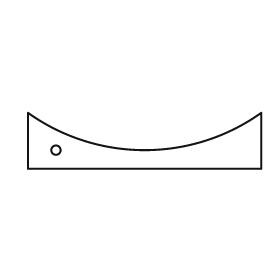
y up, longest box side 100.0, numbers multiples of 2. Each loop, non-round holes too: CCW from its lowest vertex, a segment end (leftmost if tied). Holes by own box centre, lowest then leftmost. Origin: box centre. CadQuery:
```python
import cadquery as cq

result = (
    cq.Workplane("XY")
    .moveTo(-50.0, -12.0)
    .lineTo(50.0, -12.0)
    .lineTo(50.0, 12.0)
    .threePointArc((0.0, -4.0), (-50.0, 12.0))
    .close()
    .moveTo(-38.0, -4.0)
    .circle(2.0)
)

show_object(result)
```